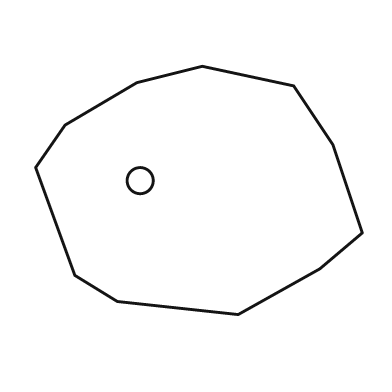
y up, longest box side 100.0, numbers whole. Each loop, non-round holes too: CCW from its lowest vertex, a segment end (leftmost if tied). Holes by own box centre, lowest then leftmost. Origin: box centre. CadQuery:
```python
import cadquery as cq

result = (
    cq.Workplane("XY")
    .moveTo(12.0, -38.0)
    .lineTo(37.0, -24.0)
    .lineTo(50.0, -13.0)
    .lineTo(41.0, 14.0)
    .lineTo(29.0, 32.0)
    .lineTo(1.0, 38.0)
    .lineTo(-19.0, 33.0)
    .lineTo(-41.0, 20.0)
    .lineTo(-50.0, 7.0)
    .lineTo(-38.0, -26.0)
    .lineTo(-25.0, -34.0)
    .close()
    .moveTo(-18.0, 3.0)
    .circle(4.0)
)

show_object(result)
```